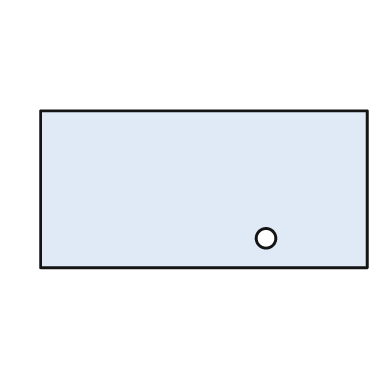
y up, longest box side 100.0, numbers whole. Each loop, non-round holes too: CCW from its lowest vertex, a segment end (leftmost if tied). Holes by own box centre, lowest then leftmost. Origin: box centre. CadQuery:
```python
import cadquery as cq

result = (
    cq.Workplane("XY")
    .moveTo(-50.0, -24.0)
    .lineTo(50.0, -24.0)
    .lineTo(50.0, 24.0)
    .lineTo(-50.0, 24.0)
    .close()
    .moveTo(19.0, -15.0)
    .circle(3.0)
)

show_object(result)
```